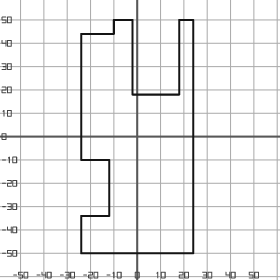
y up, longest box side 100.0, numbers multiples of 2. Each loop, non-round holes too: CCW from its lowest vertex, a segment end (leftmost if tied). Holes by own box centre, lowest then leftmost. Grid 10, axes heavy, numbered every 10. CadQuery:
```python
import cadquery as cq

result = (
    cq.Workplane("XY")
    .moveTo(-24.0, -50.0)
    .lineTo(24.0, -50.0)
    .lineTo(24.0, 50.0)
    .lineTo(18.0, 50.0)
    .lineTo(18.0, 18.0)
    .lineTo(-2.0, 18.0)
    .lineTo(-2.0, 50.0)
    .lineTo(-10.0, 50.0)
    .lineTo(-10.0, 44.0)
    .lineTo(-24.0, 44.0)
    .lineTo(-24.0, -10.0)
    .lineTo(-12.0, -10.0)
    .lineTo(-12.0, -34.0)
    .lineTo(-24.0, -34.0)
    .close()
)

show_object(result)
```